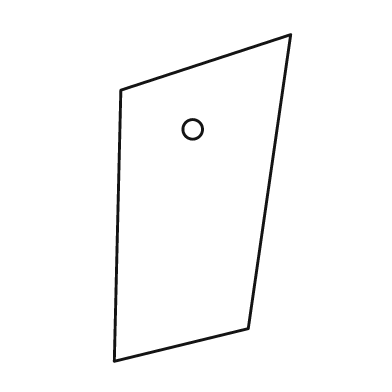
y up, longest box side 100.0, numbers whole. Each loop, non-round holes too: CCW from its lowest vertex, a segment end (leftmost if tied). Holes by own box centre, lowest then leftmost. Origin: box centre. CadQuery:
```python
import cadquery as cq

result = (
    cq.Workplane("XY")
    .moveTo(-27.0, -50.0)
    .lineTo(14.0, -40.0)
    .lineTo(27.0, 50.0)
    .lineTo(-25.0, 33.0)
    .close()
    .moveTo(-3.0, 21.0)
    .circle(3.0)
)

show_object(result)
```